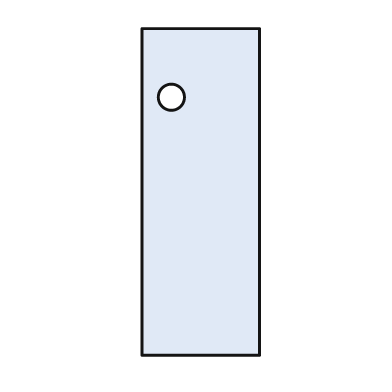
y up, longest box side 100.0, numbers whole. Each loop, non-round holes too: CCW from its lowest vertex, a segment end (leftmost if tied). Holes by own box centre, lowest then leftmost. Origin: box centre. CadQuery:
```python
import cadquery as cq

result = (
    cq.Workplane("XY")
    .moveTo(-18.0, -50.0)
    .lineTo(18.0, -50.0)
    .lineTo(18.0, 50.0)
    .lineTo(-18.0, 50.0)
    .close()
    .moveTo(-9.0, 29.0)
    .circle(4.0)
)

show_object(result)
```